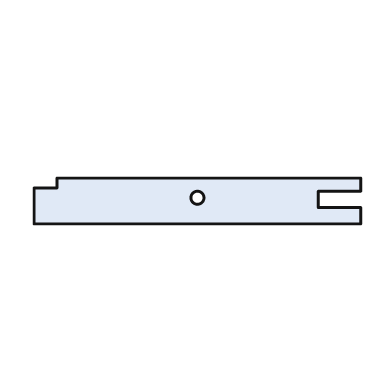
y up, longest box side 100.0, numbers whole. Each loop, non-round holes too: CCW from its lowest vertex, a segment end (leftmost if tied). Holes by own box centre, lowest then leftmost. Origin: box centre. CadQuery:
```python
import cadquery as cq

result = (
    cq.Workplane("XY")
    .moveTo(-50.0, -7.0)
    .lineTo(50.0, -7.0)
    .lineTo(50.0, -2.0)
    .lineTo(37.0, -2.0)
    .lineTo(37.0, 3.0)
    .lineTo(50.0, 3.0)
    .lineTo(50.0, 7.0)
    .lineTo(-43.0, 7.0)
    .lineTo(-43.0, 4.0)
    .lineTo(-50.0, 4.0)
    .close()
    .moveTo(0.0, 1.0)
    .circle(2.0)
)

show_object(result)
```